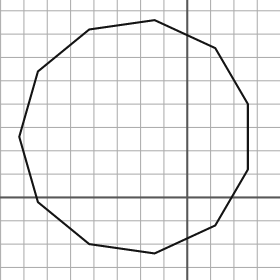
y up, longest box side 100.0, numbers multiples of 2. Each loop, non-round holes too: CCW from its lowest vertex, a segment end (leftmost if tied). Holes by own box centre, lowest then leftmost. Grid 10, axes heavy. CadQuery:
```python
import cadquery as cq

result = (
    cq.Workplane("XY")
    .moveTo(-14.0, -24.0)
    .lineTo(12.0, -12.0)
    .lineTo(26.0, 12.0)
    .lineTo(26.0, 40.0)
    .lineTo(12.0, 64.0)
    .lineTo(-14.0, 76.0)
    .lineTo(-42.0, 72.0)
    .lineTo(-64.0, 54.0)
    .lineTo(-72.0, 26.0)
    .lineTo(-64.0, -2.0)
    .lineTo(-42.0, -20.0)
    .close()
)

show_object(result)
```